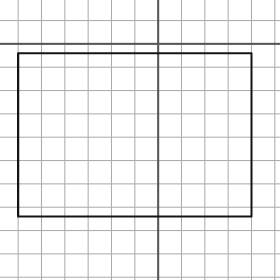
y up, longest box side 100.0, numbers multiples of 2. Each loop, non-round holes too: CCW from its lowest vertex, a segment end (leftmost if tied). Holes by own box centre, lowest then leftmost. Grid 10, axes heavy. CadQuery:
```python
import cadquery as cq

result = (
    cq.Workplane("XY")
    .moveTo(-60.0, -74.0)
    .lineTo(40.0, -74.0)
    .lineTo(40.0, -4.0)
    .lineTo(-60.0, -4.0)
    .close()
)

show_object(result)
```